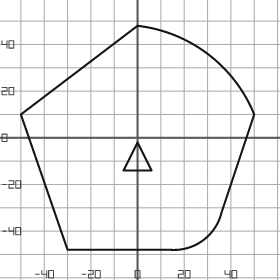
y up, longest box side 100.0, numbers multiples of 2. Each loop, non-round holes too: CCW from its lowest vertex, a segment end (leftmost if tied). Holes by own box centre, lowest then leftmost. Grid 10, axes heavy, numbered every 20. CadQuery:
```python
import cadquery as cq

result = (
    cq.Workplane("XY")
    .moveTo(-30.0, -48.0)
    .lineTo(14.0, -48.0)
    .threePointArc((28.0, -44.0), (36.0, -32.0))
    .lineTo(50.0, 10.0)
    .threePointArc((30.0, 36.0), (0.0, 48.0))
    .lineTo(-50.0, 10.0)
    .close()
    .moveTo(-6.0, -14.0)
    .lineTo(6.0, -14.0)
    .lineTo(0.0, -2.0)
    .close()
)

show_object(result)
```